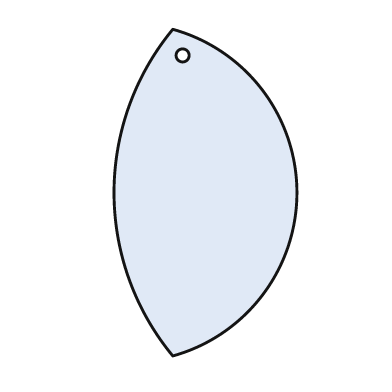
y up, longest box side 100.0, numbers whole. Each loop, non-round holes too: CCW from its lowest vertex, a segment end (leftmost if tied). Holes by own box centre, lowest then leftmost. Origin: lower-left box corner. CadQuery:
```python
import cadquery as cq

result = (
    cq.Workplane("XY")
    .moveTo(18.0, 0.0)
    .threePointArc((56.0, 50.0), (18.0, 100.0))
    .threePointArc((0.0, 50.0), (18.0, 0.0))
    .close()
    .moveTo(21.0, 92.0)
    .circle(2.0)
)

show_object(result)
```